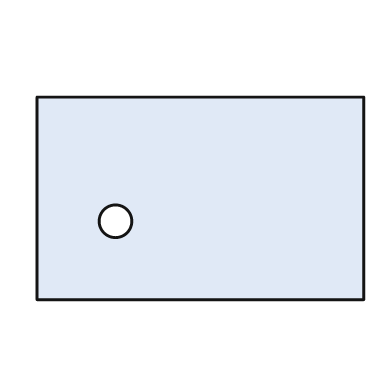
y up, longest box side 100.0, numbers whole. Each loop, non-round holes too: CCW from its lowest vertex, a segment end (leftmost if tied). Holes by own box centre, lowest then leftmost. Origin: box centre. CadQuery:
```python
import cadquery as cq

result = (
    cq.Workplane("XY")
    .moveTo(-50.0, -31.0)
    .lineTo(50.0, -31.0)
    .lineTo(50.0, 31.0)
    .lineTo(-50.0, 31.0)
    .close()
    .moveTo(-26.0, -7.0)
    .circle(5.0)
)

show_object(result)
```